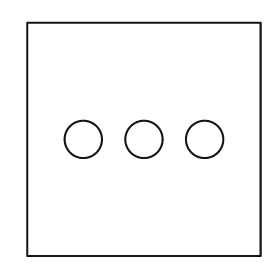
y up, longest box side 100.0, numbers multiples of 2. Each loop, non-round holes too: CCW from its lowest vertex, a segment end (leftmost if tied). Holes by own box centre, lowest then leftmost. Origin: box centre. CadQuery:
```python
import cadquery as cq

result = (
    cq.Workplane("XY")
    .moveTo(-50.0, -50.0)
    .lineTo(50.0, -50.0)
    .lineTo(50.0, 50.0)
    .lineTo(-50.0, 50.0)
    .close()
    .moveTo(-26.0, 0.0)
    .circle(8.0)
    .moveTo(0.0, 0.0)
    .circle(8.0)
    .moveTo(26.0, 0.0)
    .circle(8.0)
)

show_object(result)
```